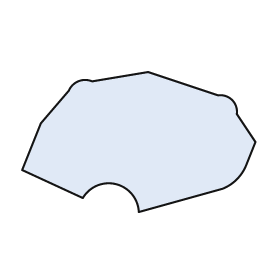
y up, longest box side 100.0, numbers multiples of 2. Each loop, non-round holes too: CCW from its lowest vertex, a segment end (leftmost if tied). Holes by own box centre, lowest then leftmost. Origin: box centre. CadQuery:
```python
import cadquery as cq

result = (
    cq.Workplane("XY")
    .moveTo(0.0, -30.0)
    .lineTo(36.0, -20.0)
    .threePointArc((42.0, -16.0), (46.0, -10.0))
    .lineTo(50.0, 0.0)
    .lineTo(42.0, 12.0)
    .threePointArc((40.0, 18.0), (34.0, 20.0))
    .lineTo(4.0, 30.0)
    .lineTo(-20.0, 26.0)
    .threePointArc((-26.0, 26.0), (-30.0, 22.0))
    .lineTo(-42.0, 8.0)
    .lineTo(-50.0, -12.0)
    .lineTo(-24.0, -24.0)
    .threePointArc((-10.0, -18.0), (0.0, -30.0))
    .close()
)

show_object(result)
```